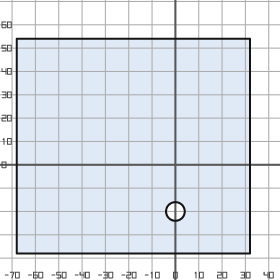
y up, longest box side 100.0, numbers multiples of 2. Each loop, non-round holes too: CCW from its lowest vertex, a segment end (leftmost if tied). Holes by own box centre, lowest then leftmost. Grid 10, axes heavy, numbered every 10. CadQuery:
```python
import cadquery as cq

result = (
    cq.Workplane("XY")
    .moveTo(-68.0, -38.0)
    .lineTo(32.0, -38.0)
    .lineTo(32.0, 54.0)
    .lineTo(-68.0, 54.0)
    .close()
    .moveTo(0.0, -20.0)
    .circle(4.0)
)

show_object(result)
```